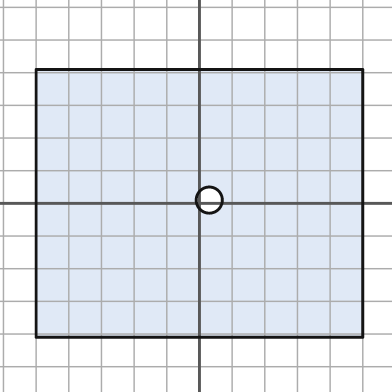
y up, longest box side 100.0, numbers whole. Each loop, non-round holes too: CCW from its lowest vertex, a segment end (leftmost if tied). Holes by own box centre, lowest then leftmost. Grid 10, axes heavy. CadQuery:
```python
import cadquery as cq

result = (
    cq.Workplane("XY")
    .moveTo(-50.0, -41.0)
    .lineTo(50.0, -41.0)
    .lineTo(50.0, 41.0)
    .lineTo(-50.0, 41.0)
    .close()
    .moveTo(3.0, 1.0)
    .circle(4.0)
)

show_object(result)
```